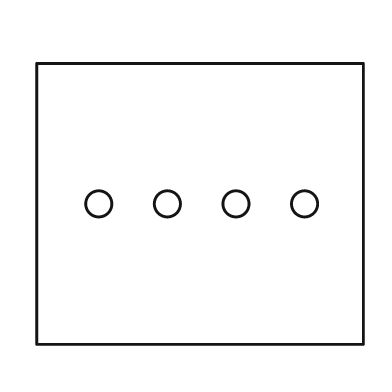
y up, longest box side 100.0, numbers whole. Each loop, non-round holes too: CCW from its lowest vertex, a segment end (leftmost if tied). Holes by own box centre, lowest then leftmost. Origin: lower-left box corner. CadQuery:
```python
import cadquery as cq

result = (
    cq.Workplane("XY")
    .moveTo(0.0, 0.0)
    .lineTo(100.0, 0.0)
    .lineTo(100.0, 86.0)
    .lineTo(0.0, 86.0)
    .close()
    .moveTo(19.0, 43.0)
    .circle(4.0)
    .moveTo(40.0, 43.0)
    .circle(4.0)
    .moveTo(61.0, 43.0)
    .circle(4.0)
    .moveTo(82.0, 43.0)
    .circle(4.0)
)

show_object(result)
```